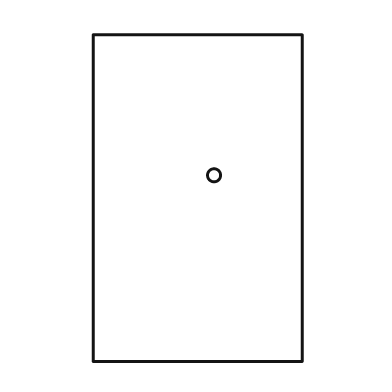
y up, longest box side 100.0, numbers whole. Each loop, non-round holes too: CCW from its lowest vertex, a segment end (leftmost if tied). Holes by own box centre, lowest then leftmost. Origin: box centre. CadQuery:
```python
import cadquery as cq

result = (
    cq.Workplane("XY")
    .moveTo(-32.0, -50.0)
    .lineTo(32.0, -50.0)
    .lineTo(32.0, 50.0)
    .lineTo(-32.0, 50.0)
    .close()
    .moveTo(5.0, 7.0)
    .circle(2.0)
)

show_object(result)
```